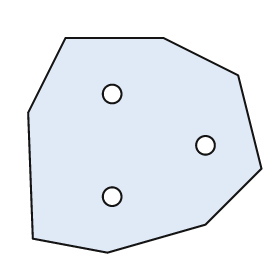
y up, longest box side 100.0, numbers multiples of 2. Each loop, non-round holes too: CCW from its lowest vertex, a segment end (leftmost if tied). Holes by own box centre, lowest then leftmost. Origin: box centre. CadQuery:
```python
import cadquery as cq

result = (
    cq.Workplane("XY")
    .moveTo(-16.0, -46.0)
    .lineTo(26.0, -34.0)
    .lineTo(50.0, -10.0)
    .lineTo(40.0, 30.0)
    .lineTo(8.0, 46.0)
    .lineTo(-34.0, 46.0)
    .lineTo(-50.0, 14.0)
    .lineTo(-48.0, -40.0)
    .close()
    .moveTo(-14.0, -22.0)
    .circle(4.0)
    .moveTo(26.0, 0.0)
    .circle(4.0)
    .moveTo(-14.0, 22.0)
    .circle(4.0)
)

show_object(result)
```